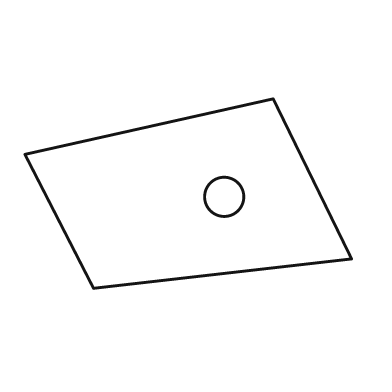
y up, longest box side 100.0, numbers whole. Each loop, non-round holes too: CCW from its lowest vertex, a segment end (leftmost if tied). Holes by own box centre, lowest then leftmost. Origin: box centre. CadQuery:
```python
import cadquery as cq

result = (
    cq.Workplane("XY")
    .moveTo(-29.0, -29.0)
    .lineTo(50.0, -20.0)
    .lineTo(26.0, 29.0)
    .lineTo(-50.0, 12.0)
    .close()
    .moveTo(11.0, -1.0)
    .circle(6.0)
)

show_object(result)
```